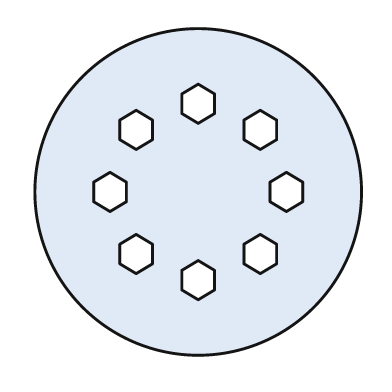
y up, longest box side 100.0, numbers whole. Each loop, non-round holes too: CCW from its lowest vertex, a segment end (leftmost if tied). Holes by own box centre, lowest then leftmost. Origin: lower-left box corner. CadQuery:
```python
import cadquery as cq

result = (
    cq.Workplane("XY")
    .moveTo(50.0, 50.0)
    .circle(50.0)
    .moveTo(50.0, 17.0)
    .lineTo(55.0, 20.0)
    .lineTo(55.0, 26.0)
    .lineTo(50.0, 29.0)
    .lineTo(45.0, 26.0)
    .lineTo(45.0, 20.0)
    .close()
    .moveTo(31.0, 25.0)
    .lineTo(36.0, 28.0)
    .lineTo(36.0, 34.0)
    .lineTo(31.0, 37.0)
    .lineTo(26.0, 34.0)
    .lineTo(26.0, 28.0)
    .close()
    .moveTo(69.0, 25.0)
    .lineTo(74.0, 28.0)
    .lineTo(74.0, 34.0)
    .lineTo(69.0, 37.0)
    .lineTo(64.0, 34.0)
    .lineTo(64.0, 28.0)
    .close()
    .moveTo(23.0, 44.0)
    .lineTo(28.0, 47.0)
    .lineTo(28.0, 53.0)
    .lineTo(23.0, 56.0)
    .lineTo(18.0, 53.0)
    .lineTo(18.0, 47.0)
    .close()
    .moveTo(77.0, 44.0)
    .lineTo(82.0, 47.0)
    .lineTo(82.0, 53.0)
    .lineTo(77.0, 56.0)
    .lineTo(72.0, 53.0)
    .lineTo(72.0, 47.0)
    .close()
    .moveTo(31.0, 63.0)
    .lineTo(36.0, 66.0)
    .lineTo(36.0, 72.0)
    .lineTo(31.0, 75.0)
    .lineTo(26.0, 72.0)
    .lineTo(26.0, 66.0)
    .close()
    .moveTo(69.0, 63.0)
    .lineTo(74.0, 66.0)
    .lineTo(74.0, 72.0)
    .lineTo(69.0, 75.0)
    .lineTo(64.0, 72.0)
    .lineTo(64.0, 66.0)
    .close()
    .moveTo(50.0, 71.0)
    .lineTo(55.0, 74.0)
    .lineTo(55.0, 80.0)
    .lineTo(50.0, 83.0)
    .lineTo(45.0, 80.0)
    .lineTo(45.0, 74.0)
    .close()
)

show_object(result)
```